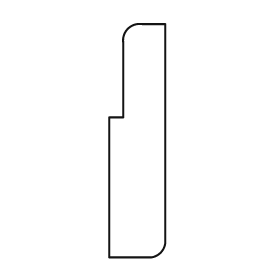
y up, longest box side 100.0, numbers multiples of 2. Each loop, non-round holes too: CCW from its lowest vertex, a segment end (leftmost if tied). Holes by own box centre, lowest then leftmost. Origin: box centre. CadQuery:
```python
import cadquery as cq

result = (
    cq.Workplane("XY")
    .moveTo(-12.0, -50.0)
    .lineTo(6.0, -50.0)
    .threePointArc((10.0, -48.0), (12.0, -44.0))
    .lineTo(12.0, 50.0)
    .lineTo(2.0, 50.0)
    .threePointArc((-4.0, 48.0), (-6.0, 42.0))
    .lineTo(-6.0, 10.0)
    .lineTo(-12.0, 10.0)
    .close()
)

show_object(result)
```